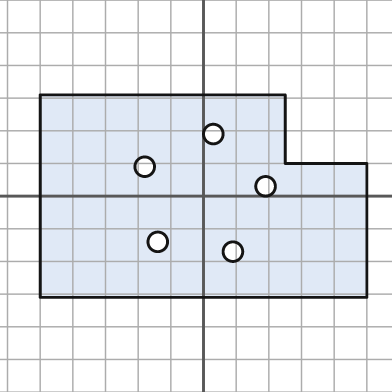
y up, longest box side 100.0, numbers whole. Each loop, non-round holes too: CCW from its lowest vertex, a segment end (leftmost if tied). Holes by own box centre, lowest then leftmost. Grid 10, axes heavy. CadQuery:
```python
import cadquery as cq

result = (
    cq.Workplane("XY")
    .moveTo(-50.0, -31.0)
    .lineTo(50.0, -31.0)
    .lineTo(50.0, 10.0)
    .lineTo(25.0, 10.0)
    .lineTo(25.0, 31.0)
    .lineTo(-50.0, 31.0)
    .close()
    .moveTo(9.0, -17.0)
    .circle(3.0)
    .moveTo(-14.0, -14.0)
    .circle(3.0)
    .moveTo(19.0, 3.0)
    .circle(3.0)
    .moveTo(-18.0, 9.0)
    .circle(3.0)
    .moveTo(3.0, 19.0)
    .circle(3.0)
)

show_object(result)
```